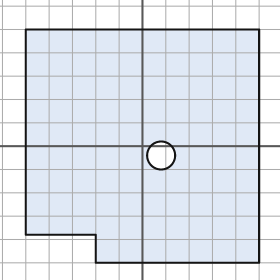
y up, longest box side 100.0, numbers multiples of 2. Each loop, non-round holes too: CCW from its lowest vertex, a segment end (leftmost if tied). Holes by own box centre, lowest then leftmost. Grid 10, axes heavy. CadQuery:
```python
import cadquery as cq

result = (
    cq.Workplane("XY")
    .moveTo(-20.0, -50.0)
    .lineTo(50.0, -50.0)
    .lineTo(50.0, 50.0)
    .lineTo(-50.0, 50.0)
    .lineTo(-50.0, -38.0)
    .lineTo(-20.0, -38.0)
    .close()
    .moveTo(8.0, -4.0)
    .circle(6.0)
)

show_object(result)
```